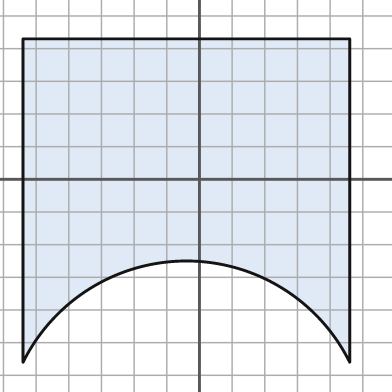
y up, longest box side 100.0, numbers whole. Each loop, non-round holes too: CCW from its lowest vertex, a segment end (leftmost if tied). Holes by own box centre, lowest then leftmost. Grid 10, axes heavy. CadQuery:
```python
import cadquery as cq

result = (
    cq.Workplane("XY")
    .moveTo(-54.0, -56.0)
    .threePointArc((-4.0, -25.0), (46.0, -56.0))
    .lineTo(46.0, 43.0)
    .lineTo(-54.0, 43.0)
    .close()
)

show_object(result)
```